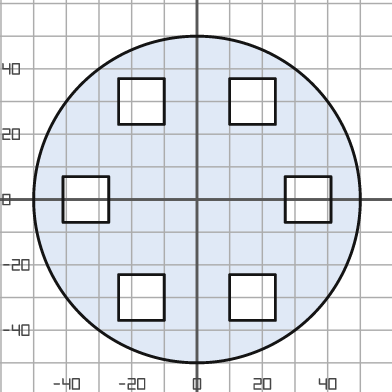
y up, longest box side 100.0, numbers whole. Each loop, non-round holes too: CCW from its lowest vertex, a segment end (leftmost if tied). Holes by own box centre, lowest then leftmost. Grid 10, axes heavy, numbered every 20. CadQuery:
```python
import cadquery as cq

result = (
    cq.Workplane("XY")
    .moveTo(0.0, 0.0)
    .circle(50.0)
    .moveTo(-24.0, -37.0)
    .lineTo(-10.0, -37.0)
    .lineTo(-10.0, -23.0)
    .lineTo(-24.0, -23.0)
    .close()
    .moveTo(10.0, -37.0)
    .lineTo(24.0, -37.0)
    .lineTo(24.0, -23.0)
    .lineTo(10.0, -23.0)
    .close()
    .moveTo(-41.0, -7.0)
    .lineTo(-27.0, -7.0)
    .lineTo(-27.0, 7.0)
    .lineTo(-41.0, 7.0)
    .close()
    .moveTo(27.0, -7.0)
    .lineTo(41.0, -7.0)
    .lineTo(41.0, 7.0)
    .lineTo(27.0, 7.0)
    .close()
    .moveTo(-24.0, 23.0)
    .lineTo(-10.0, 23.0)
    .lineTo(-10.0, 37.0)
    .lineTo(-24.0, 37.0)
    .close()
    .moveTo(10.0, 23.0)
    .lineTo(24.0, 23.0)
    .lineTo(24.0, 37.0)
    .lineTo(10.0, 37.0)
    .close()
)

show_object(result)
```